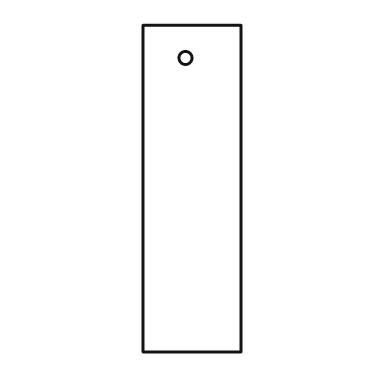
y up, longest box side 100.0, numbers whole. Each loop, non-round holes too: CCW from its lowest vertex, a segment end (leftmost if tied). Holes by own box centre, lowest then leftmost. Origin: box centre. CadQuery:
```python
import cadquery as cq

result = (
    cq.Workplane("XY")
    .moveTo(-15.0, -50.0)
    .lineTo(15.0, -50.0)
    .lineTo(15.0, 50.0)
    .lineTo(-15.0, 50.0)
    .close()
    .moveTo(-2.0, 40.0)
    .circle(2.0)
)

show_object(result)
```